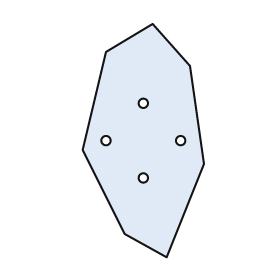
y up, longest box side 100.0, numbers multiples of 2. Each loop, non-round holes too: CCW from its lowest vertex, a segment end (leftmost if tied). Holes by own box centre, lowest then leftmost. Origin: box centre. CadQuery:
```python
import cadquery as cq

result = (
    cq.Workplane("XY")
    .moveTo(10.0, -50.0)
    .lineTo(26.0, -10.0)
    .lineTo(20.0, 32.0)
    .lineTo(4.0, 50.0)
    .lineTo(-16.0, 38.0)
    .lineTo(-26.0, -4.0)
    .lineTo(-8.0, -40.0)
    .close()
    .moveTo(0.0, -16.0)
    .circle(2.0)
    .moveTo(-16.0, 0.0)
    .circle(2.0)
    .moveTo(16.0, 0.0)
    .circle(2.0)
    .moveTo(0.0, 16.0)
    .circle(2.0)
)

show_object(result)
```